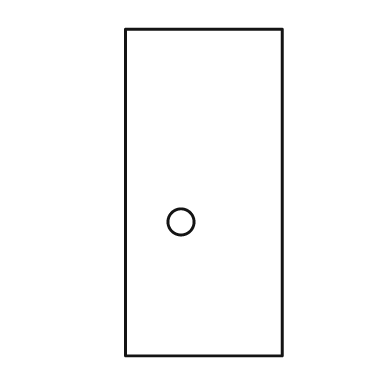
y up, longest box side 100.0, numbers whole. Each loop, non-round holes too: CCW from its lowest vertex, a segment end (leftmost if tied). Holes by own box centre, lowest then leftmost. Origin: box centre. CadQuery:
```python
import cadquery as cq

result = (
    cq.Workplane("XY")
    .moveTo(-24.0, -50.0)
    .lineTo(24.0, -50.0)
    .lineTo(24.0, 50.0)
    .lineTo(-24.0, 50.0)
    .close()
    .moveTo(-7.0, -9.0)
    .circle(4.0)
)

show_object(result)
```